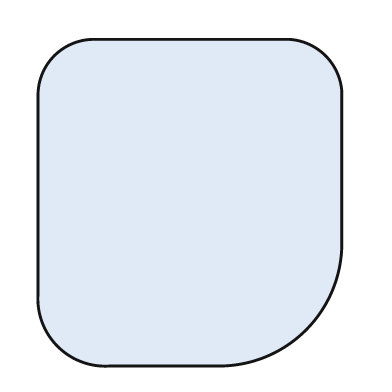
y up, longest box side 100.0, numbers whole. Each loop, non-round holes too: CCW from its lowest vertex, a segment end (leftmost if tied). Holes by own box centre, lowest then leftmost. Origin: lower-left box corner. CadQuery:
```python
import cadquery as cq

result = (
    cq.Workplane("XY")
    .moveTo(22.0, 0.0)
    .lineTo(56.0, 0.0)
    .threePointArc((82.0, 11.0), (93.0, 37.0))
    .lineTo(93.0, 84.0)
    .threePointArc((88.0, 95.0), (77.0, 100.0))
    .lineTo(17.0, 100.0)
    .threePointArc((5.0, 95.0), (0.0, 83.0))
    .lineTo(0.0, 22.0)
    .threePointArc((6.0, 6.0), (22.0, 0.0))
    .close()
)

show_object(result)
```